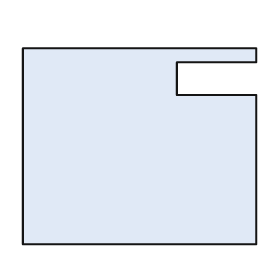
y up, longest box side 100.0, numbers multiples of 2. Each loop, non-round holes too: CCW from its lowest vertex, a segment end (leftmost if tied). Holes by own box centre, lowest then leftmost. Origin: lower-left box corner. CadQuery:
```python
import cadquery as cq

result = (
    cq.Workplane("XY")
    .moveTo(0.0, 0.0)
    .lineTo(100.0, 0.0)
    .lineTo(100.0, 64.0)
    .lineTo(66.0, 64.0)
    .lineTo(66.0, 78.0)
    .lineTo(100.0, 78.0)
    .lineTo(100.0, 84.0)
    .lineTo(0.0, 84.0)
    .close()
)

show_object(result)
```